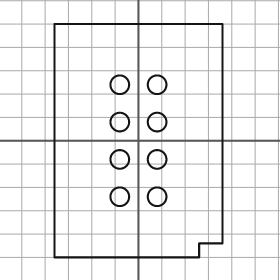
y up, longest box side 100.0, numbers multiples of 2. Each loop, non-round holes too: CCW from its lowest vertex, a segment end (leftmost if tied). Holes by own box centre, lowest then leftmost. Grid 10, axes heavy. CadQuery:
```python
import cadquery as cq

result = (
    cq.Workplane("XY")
    .moveTo(-36.0, -50.0)
    .lineTo(26.0, -50.0)
    .lineTo(26.0, -44.0)
    .lineTo(36.0, -44.0)
    .lineTo(36.0, 50.0)
    .lineTo(-36.0, 50.0)
    .close()
    .moveTo(-8.0, -24.0)
    .circle(4.0)
    .moveTo(8.0, -24.0)
    .circle(4.0)
    .moveTo(-8.0, -8.0)
    .circle(4.0)
    .moveTo(8.0, -8.0)
    .circle(4.0)
    .moveTo(-8.0, 8.0)
    .circle(4.0)
    .moveTo(8.0, 8.0)
    .circle(4.0)
    .moveTo(-8.0, 24.0)
    .circle(4.0)
    .moveTo(8.0, 24.0)
    .circle(4.0)
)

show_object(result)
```